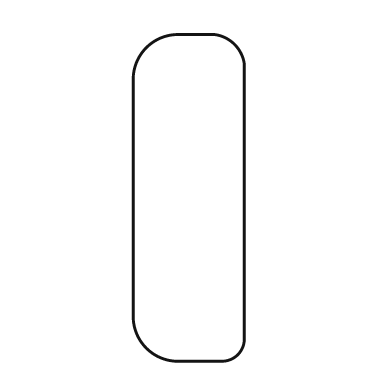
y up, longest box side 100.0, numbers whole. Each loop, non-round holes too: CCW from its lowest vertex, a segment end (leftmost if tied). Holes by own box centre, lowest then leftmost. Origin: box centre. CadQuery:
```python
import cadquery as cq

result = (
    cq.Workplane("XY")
    .moveTo(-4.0, -50.0)
    .lineTo(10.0, -50.0)
    .threePointArc((15.0, -48.0), (17.0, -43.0))
    .lineTo(17.0, 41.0)
    .threePointArc((14.0, 47.0), (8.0, 50.0))
    .lineTo(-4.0, 50.0)
    .threePointArc((-13.0, 46.0), (-17.0, 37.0))
    .lineTo(-17.0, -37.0)
    .threePointArc((-13.0, -46.0), (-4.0, -50.0))
    .close()
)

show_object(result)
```